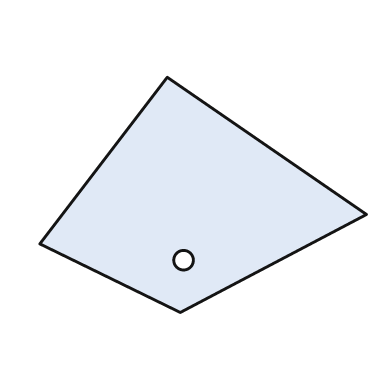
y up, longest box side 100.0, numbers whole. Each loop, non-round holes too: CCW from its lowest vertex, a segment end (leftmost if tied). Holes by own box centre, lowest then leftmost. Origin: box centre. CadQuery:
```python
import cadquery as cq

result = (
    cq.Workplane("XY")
    .moveTo(-7.0, -36.0)
    .lineTo(50.0, -6.0)
    .lineTo(-11.0, 36.0)
    .lineTo(-50.0, -15.0)
    .close()
    .moveTo(-6.0, -20.0)
    .circle(3.0)
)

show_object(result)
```